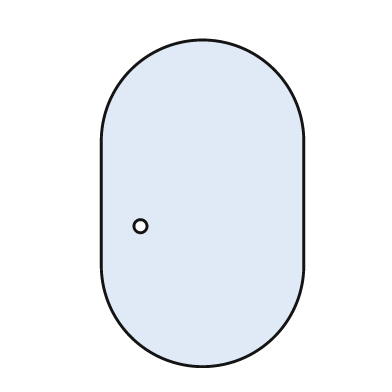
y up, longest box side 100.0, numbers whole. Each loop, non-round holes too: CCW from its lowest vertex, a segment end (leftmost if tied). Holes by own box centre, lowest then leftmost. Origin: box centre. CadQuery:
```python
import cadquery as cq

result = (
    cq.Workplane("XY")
    .moveTo(-31.0, -19.0)
    .threePointArc((0.0, -50.0), (31.0, -19.0))
    .lineTo(31.0, 19.0)
    .threePointArc((0.0, 50.0), (-31.0, 19.0))
    .close()
    .moveTo(-19.0, -7.0)
    .circle(2.0)
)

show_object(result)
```